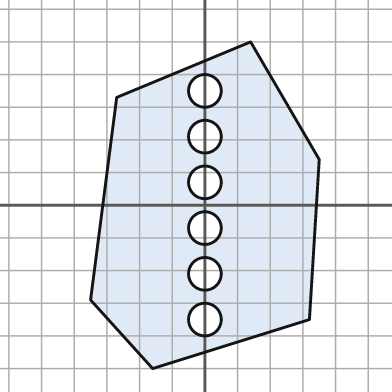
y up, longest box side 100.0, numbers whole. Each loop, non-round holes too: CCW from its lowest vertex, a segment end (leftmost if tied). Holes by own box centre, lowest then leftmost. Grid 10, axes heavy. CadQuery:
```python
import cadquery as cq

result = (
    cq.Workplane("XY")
    .moveTo(-16.0, -50.0)
    .lineTo(32.0, -35.0)
    .lineTo(35.0, 14.0)
    .lineTo(14.0, 50.0)
    .lineTo(-27.0, 33.0)
    .lineTo(-35.0, -29.0)
    .close()
    .moveTo(0.0, -35.0)
    .circle(5.0)
    .moveTo(0.0, -21.0)
    .circle(5.0)
    .moveTo(0.0, -7.0)
    .circle(5.0)
    .moveTo(0.0, 7.0)
    .circle(5.0)
    .moveTo(0.0, 21.0)
    .circle(5.0)
    .moveTo(0.0, 35.0)
    .circle(5.0)
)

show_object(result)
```